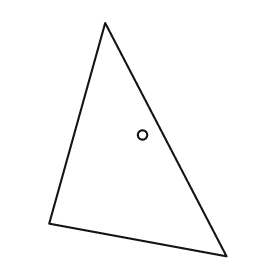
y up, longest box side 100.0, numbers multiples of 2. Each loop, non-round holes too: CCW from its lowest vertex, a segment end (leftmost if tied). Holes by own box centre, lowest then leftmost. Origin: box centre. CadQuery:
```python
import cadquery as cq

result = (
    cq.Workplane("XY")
    .moveTo(38.0, -50.0)
    .lineTo(-14.0, 50.0)
    .lineTo(-38.0, -36.0)
    .close()
    .moveTo(2.0, 2.0)
    .circle(2.0)
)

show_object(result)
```